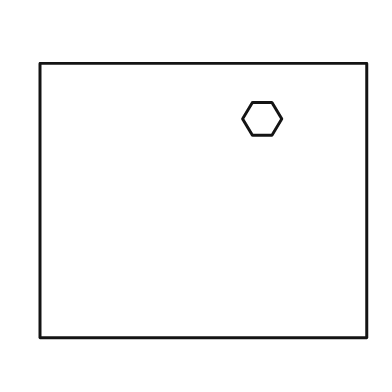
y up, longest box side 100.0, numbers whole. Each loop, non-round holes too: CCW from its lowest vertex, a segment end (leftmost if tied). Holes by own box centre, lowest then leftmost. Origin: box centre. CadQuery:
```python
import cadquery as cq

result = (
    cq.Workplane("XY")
    .moveTo(-50.0, -42.0)
    .lineTo(50.0, -42.0)
    .lineTo(50.0, 42.0)
    .lineTo(-50.0, 42.0)
    .close()
    .moveTo(15.0, 20.0)
    .lineTo(21.0, 20.0)
    .lineTo(24.0, 25.0)
    .lineTo(21.0, 30.0)
    .lineTo(15.0, 30.0)
    .lineTo(12.0, 25.0)
    .close()
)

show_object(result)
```